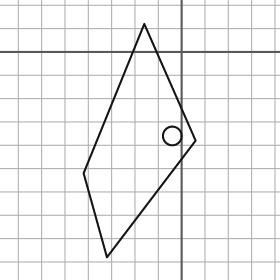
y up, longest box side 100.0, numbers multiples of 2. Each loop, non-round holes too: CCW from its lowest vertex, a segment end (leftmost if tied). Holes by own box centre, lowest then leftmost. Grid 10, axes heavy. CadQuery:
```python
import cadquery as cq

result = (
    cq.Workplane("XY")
    .moveTo(-32.0, -88.0)
    .lineTo(6.0, -38.0)
    .lineTo(-16.0, 12.0)
    .lineTo(-42.0, -52.0)
    .close()
    .moveTo(-4.0, -36.0)
    .circle(4.0)
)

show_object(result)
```